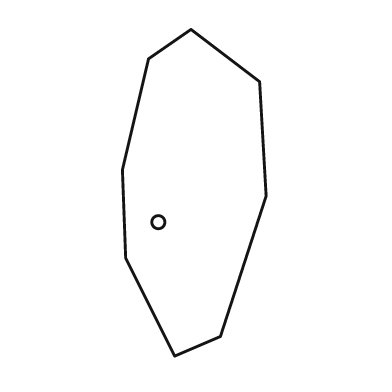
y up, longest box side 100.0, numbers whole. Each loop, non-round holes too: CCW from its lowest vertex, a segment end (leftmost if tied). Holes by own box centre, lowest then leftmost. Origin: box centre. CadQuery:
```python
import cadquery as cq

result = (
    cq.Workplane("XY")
    .moveTo(-6.0, -50.0)
    .lineTo(8.0, -44.0)
    .lineTo(22.0, -1.0)
    .lineTo(20.0, 34.0)
    .lineTo(-1.0, 50.0)
    .lineTo(-14.0, 41.0)
    .lineTo(-22.0, 7.0)
    .lineTo(-21.0, -20.0)
    .close()
    .moveTo(-11.0, -9.0)
    .circle(2.0)
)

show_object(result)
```